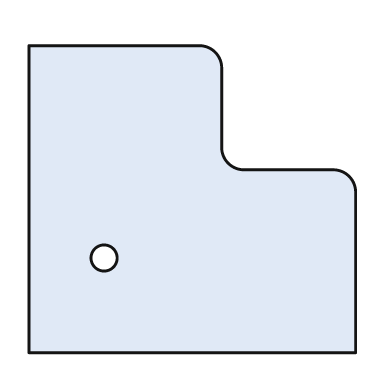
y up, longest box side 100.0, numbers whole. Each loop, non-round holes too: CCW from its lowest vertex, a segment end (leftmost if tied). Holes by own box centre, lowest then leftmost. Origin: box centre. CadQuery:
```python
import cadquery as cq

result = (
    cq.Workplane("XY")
    .moveTo(-50.0, -47.0)
    .lineTo(50.0, -47.0)
    .lineTo(50.0, 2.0)
    .threePointArc((48.0, 7.0), (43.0, 9.0))
    .lineTo(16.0, 9.0)
    .threePointArc((11.0, 11.0), (9.0, 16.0))
    .lineTo(9.0, 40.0)
    .threePointArc((7.0, 45.0), (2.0, 47.0))
    .lineTo(-50.0, 47.0)
    .close()
    .moveTo(-27.0, -18.0)
    .circle(4.0)
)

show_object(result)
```